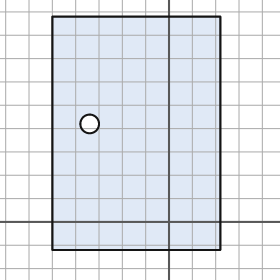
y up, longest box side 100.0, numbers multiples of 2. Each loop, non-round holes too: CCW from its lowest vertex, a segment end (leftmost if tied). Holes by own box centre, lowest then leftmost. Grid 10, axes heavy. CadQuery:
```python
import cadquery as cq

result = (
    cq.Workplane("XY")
    .moveTo(-50.0, -12.0)
    .lineTo(22.0, -12.0)
    .lineTo(22.0, 88.0)
    .lineTo(-50.0, 88.0)
    .close()
    .moveTo(-34.0, 42.0)
    .circle(4.0)
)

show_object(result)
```